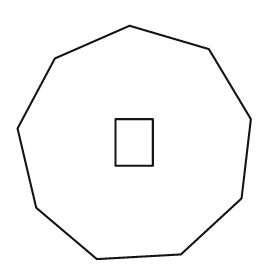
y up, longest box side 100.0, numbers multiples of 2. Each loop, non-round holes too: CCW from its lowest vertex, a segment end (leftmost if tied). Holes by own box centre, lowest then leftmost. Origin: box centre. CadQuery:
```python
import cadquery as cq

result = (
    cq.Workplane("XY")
    .moveTo(-16.0, -50.0)
    .lineTo(20.0, -48.0)
    .lineTo(46.0, -24.0)
    .lineTo(50.0, 10.0)
    .lineTo(32.0, 40.0)
    .lineTo(-2.0, 50.0)
    .lineTo(-34.0, 36.0)
    .lineTo(-50.0, 6.0)
    .lineTo(-42.0, -28.0)
    .close()
    .moveTo(-8.0, -10.0)
    .lineTo(8.0, -10.0)
    .lineTo(8.0, 10.0)
    .lineTo(-8.0, 10.0)
    .close()
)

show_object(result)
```